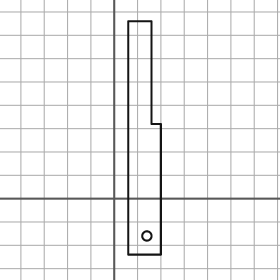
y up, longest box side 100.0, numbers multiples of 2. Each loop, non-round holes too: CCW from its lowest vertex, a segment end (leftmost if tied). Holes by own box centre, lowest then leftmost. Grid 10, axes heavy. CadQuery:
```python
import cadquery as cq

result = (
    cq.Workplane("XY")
    .moveTo(6.0, -24.0)
    .lineTo(20.0, -24.0)
    .lineTo(20.0, 32.0)
    .lineTo(16.0, 32.0)
    .lineTo(16.0, 76.0)
    .lineTo(6.0, 76.0)
    .close()
    .moveTo(14.0, -16.0)
    .circle(2.0)
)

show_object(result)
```